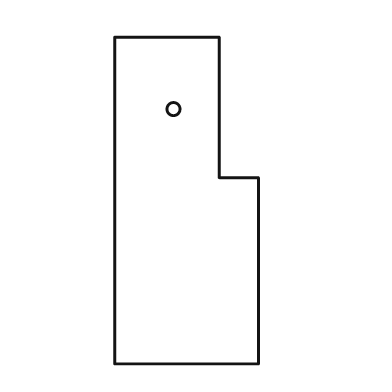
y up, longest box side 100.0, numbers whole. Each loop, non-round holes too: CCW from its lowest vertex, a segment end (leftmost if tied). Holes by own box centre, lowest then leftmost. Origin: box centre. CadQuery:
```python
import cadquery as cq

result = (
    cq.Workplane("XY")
    .moveTo(-22.0, -50.0)
    .lineTo(22.0, -50.0)
    .lineTo(22.0, 7.0)
    .lineTo(10.0, 7.0)
    .lineTo(10.0, 50.0)
    .lineTo(-22.0, 50.0)
    .close()
    .moveTo(-4.0, 28.0)
    .circle(2.0)
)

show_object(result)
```